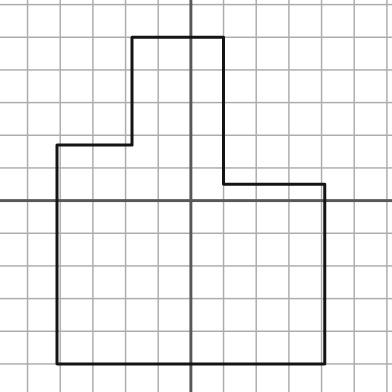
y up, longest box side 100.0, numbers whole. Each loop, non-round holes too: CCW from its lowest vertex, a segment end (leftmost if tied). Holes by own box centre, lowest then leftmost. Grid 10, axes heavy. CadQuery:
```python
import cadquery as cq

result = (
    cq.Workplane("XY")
    .moveTo(-41.0, -50.0)
    .lineTo(41.0, -50.0)
    .lineTo(41.0, 5.0)
    .lineTo(10.0, 5.0)
    .lineTo(10.0, 50.0)
    .lineTo(-18.0, 50.0)
    .lineTo(-18.0, 17.0)
    .lineTo(-41.0, 17.0)
    .close()
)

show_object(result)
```